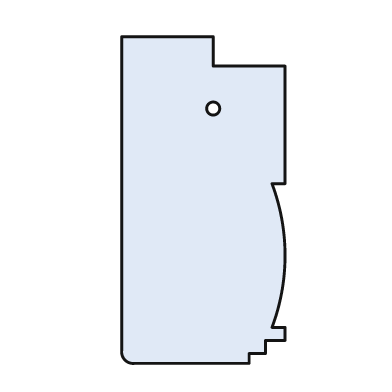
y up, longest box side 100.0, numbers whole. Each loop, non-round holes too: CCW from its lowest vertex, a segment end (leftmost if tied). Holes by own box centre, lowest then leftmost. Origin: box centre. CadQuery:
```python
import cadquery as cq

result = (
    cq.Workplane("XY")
    .moveTo(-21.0, -50.0)
    .lineTo(14.0, -50.0)
    .lineTo(14.0, -47.0)
    .lineTo(19.0, -47.0)
    .lineTo(19.0, -43.0)
    .lineTo(25.0, -43.0)
    .lineTo(25.0, -39.0)
    .lineTo(21.0, -39.0)
    .threePointArc((25.0, -17.0), (21.0, 5.0))
    .lineTo(25.0, 5.0)
    .lineTo(25.0, 41.0)
    .lineTo(3.0, 41.0)
    .lineTo(3.0, 50.0)
    .lineTo(-25.0, 50.0)
    .lineTo(-25.0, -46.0)
    .threePointArc((-24.0, -49.0), (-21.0, -50.0))
    .close()
    .moveTo(3.0, 28.0)
    .circle(2.0)
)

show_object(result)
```